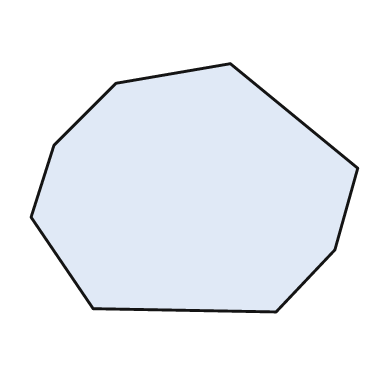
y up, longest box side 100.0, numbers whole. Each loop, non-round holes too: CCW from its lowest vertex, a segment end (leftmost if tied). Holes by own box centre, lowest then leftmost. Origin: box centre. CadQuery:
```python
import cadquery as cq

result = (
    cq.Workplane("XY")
    .moveTo(25.0, -38.0)
    .lineTo(43.0, -19.0)
    .lineTo(50.0, 6.0)
    .lineTo(11.0, 38.0)
    .lineTo(-24.0, 32.0)
    .lineTo(-43.0, 13.0)
    .lineTo(-50.0, -9.0)
    .lineTo(-31.0, -37.0)
    .close()
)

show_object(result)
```